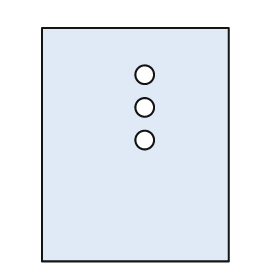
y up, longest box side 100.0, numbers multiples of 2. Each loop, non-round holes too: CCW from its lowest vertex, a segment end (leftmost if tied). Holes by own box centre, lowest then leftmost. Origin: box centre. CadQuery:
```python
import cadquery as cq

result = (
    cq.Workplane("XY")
    .moveTo(-40.0, -50.0)
    .lineTo(40.0, -50.0)
    .lineTo(40.0, 50.0)
    .lineTo(-40.0, 50.0)
    .close()
    .moveTo(4.0, 2.0)
    .circle(4.0)
    .moveTo(4.0, 16.0)
    .circle(4.0)
    .moveTo(4.0, 30.0)
    .circle(4.0)
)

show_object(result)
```